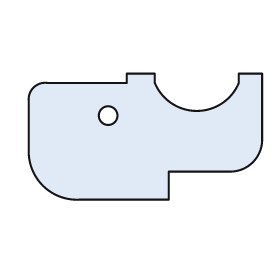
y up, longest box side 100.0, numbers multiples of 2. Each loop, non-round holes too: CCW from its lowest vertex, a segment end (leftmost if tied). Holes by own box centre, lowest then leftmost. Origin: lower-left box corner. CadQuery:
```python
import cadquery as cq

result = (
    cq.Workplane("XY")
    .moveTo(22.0, 0.0)
    .lineTo(60.0, 0.0)
    .lineTo(60.0, 12.0)
    .lineTo(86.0, 12.0)
    .threePointArc((96.0, 16.0), (100.0, 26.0))
    .lineTo(100.0, 54.0)
    .lineTo(90.0, 54.0)
    .lineTo(90.0, 50.0)
    .threePointArc((72.0, 38.0), (54.0, 50.0))
    .lineTo(54.0, 54.0)
    .lineTo(42.0, 54.0)
    .lineTo(42.0, 50.0)
    .lineTo(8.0, 50.0)
    .threePointArc((2.0, 48.0), (0.0, 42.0))
    .lineTo(0.0, 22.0)
    .threePointArc((6.0, 6.0), (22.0, 0.0))
    .close()
    .moveTo(34.0, 36.0)
    .circle(4.0)
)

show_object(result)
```